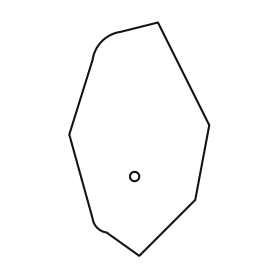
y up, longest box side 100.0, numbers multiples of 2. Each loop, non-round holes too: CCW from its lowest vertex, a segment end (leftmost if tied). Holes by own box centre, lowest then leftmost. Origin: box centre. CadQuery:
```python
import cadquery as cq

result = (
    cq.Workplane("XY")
    .moveTo(0.0, -50.0)
    .lineTo(24.0, -26.0)
    .lineTo(30.0, 6.0)
    .lineTo(8.0, 50.0)
    .lineTo(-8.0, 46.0)
    .threePointArc((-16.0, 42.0), (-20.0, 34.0))
    .lineTo(-30.0, 2.0)
    .lineTo(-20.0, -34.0)
    .threePointArc((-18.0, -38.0), (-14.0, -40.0))
    .close()
    .moveTo(-2.0, -16.0)
    .circle(2.0)
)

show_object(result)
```